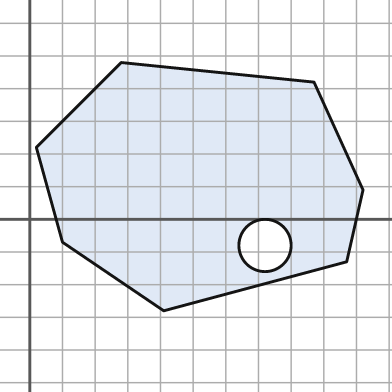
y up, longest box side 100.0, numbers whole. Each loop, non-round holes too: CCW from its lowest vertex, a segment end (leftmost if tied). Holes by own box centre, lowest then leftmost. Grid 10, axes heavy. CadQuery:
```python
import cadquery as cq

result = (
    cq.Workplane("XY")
    .moveTo(41.0, -28.0)
    .lineTo(97.0, -13.0)
    .lineTo(102.0, 9.0)
    .lineTo(87.0, 42.0)
    .lineTo(28.0, 48.0)
    .lineTo(2.0, 22.0)
    .lineTo(10.0, -7.0)
    .close()
    .moveTo(72.0, -8.0)
    .circle(8.0)
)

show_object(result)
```